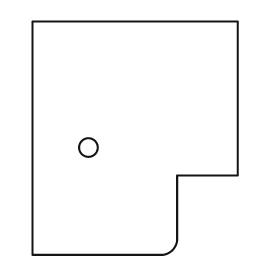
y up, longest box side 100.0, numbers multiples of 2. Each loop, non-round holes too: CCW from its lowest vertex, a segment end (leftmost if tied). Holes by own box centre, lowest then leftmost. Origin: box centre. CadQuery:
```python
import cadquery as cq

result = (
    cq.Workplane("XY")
    .moveTo(-44.0, -50.0)
    .lineTo(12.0, -50.0)
    .threePointArc((16.0, -48.0), (18.0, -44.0))
    .lineTo(18.0, -16.0)
    .lineTo(44.0, -16.0)
    .lineTo(44.0, 50.0)
    .lineTo(-44.0, 50.0)
    .close()
    .moveTo(-20.0, -4.0)
    .circle(4.0)
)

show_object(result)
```